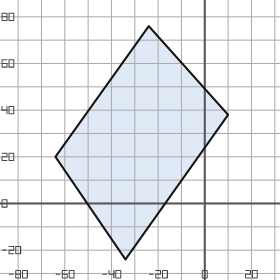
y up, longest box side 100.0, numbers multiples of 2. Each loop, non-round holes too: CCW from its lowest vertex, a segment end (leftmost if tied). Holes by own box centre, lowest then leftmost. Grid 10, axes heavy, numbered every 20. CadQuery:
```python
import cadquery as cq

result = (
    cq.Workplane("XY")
    .moveTo(-34.0, -24.0)
    .lineTo(10.0, 38.0)
    .lineTo(-24.0, 76.0)
    .lineTo(-64.0, 20.0)
    .close()
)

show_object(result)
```